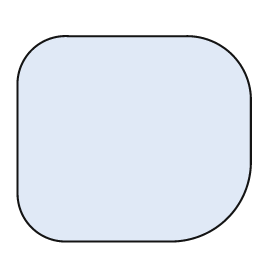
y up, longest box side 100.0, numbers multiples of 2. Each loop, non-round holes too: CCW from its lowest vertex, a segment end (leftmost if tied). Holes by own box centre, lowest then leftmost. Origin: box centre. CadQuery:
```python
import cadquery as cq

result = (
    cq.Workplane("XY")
    .moveTo(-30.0, -44.0)
    .lineTo(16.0, -44.0)
    .threePointArc((40.0, -34.0), (50.0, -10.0))
    .lineTo(50.0, 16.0)
    .threePointArc((42.0, 36.0), (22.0, 44.0))
    .lineTo(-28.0, 44.0)
    .threePointArc((-44.0, 38.0), (-50.0, 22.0))
    .lineTo(-50.0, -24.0)
    .threePointArc((-44.0, -38.0), (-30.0, -44.0))
    .close()
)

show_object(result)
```